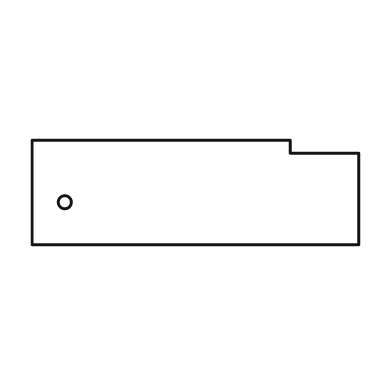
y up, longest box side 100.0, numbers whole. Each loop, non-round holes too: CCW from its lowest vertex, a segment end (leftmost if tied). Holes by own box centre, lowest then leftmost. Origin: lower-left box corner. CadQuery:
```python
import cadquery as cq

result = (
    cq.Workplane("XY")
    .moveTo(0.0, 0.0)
    .lineTo(100.0, 0.0)
    .lineTo(100.0, 28.0)
    .lineTo(79.0, 28.0)
    .lineTo(79.0, 32.0)
    .lineTo(0.0, 32.0)
    .close()
    .moveTo(10.0, 13.0)
    .circle(2.0)
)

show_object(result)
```